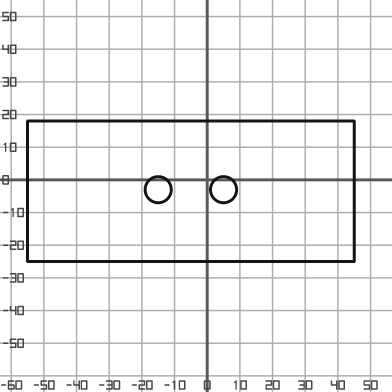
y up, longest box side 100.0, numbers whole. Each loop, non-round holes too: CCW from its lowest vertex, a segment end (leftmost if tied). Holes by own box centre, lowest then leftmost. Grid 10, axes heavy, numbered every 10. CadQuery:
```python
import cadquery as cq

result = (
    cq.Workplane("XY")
    .moveTo(-55.0, -25.0)
    .lineTo(45.0, -25.0)
    .lineTo(45.0, 18.0)
    .lineTo(-55.0, 18.0)
    .close()
    .moveTo(-15.0, -3.0)
    .circle(4.0)
    .moveTo(5.0, -3.0)
    .circle(4.0)
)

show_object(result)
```